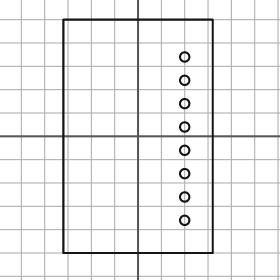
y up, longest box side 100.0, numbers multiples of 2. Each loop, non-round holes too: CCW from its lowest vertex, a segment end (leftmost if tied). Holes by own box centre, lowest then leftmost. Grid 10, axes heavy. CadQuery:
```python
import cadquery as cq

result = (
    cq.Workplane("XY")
    .moveTo(-32.0, -50.0)
    .lineTo(32.0, -50.0)
    .lineTo(32.0, 50.0)
    .lineTo(-32.0, 50.0)
    .close()
    .moveTo(20.0, -36.0)
    .circle(2.0)
    .moveTo(20.0, -26.0)
    .circle(2.0)
    .moveTo(20.0, -16.0)
    .circle(2.0)
    .moveTo(20.0, -6.0)
    .circle(2.0)
    .moveTo(20.0, 4.0)
    .circle(2.0)
    .moveTo(20.0, 14.0)
    .circle(2.0)
    .moveTo(20.0, 24.0)
    .circle(2.0)
    .moveTo(20.0, 34.0)
    .circle(2.0)
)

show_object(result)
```